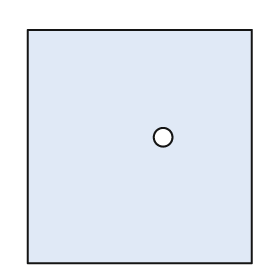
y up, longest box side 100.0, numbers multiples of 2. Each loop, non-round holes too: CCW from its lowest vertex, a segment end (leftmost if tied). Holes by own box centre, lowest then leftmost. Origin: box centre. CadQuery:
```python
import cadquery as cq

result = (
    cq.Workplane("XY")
    .moveTo(-48.0, -50.0)
    .lineTo(48.0, -50.0)
    .lineTo(48.0, 50.0)
    .lineTo(-48.0, 50.0)
    .close()
    .moveTo(10.0, 4.0)
    .circle(4.0)
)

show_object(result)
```